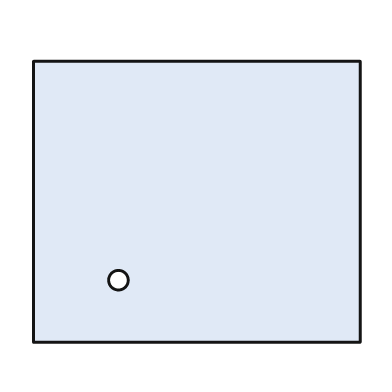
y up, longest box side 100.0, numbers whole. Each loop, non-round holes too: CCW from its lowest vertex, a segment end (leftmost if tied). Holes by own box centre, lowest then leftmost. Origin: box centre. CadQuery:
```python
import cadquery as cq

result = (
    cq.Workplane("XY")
    .moveTo(-50.0, -43.0)
    .lineTo(50.0, -43.0)
    .lineTo(50.0, 43.0)
    .lineTo(-50.0, 43.0)
    .close()
    .moveTo(-24.0, -24.0)
    .circle(3.0)
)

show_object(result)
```